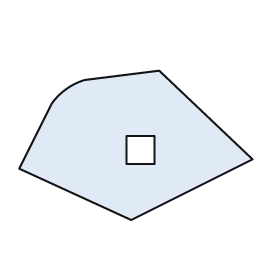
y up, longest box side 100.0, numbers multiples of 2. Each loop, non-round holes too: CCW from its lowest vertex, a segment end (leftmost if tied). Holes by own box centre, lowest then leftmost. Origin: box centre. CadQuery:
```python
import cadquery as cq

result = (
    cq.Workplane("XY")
    .moveTo(-2.0, -32.0)
    .lineTo(50.0, -6.0)
    .lineTo(10.0, 32.0)
    .lineTo(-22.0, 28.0)
    .threePointArc((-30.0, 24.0), (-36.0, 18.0))
    .lineTo(-50.0, -10.0)
    .close()
    .moveTo(-4.0, -8.0)
    .lineTo(8.0, -8.0)
    .lineTo(8.0, 4.0)
    .lineTo(-4.0, 4.0)
    .close()
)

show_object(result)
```